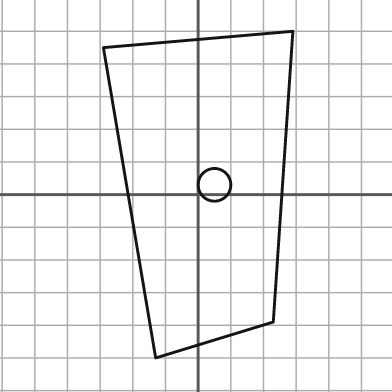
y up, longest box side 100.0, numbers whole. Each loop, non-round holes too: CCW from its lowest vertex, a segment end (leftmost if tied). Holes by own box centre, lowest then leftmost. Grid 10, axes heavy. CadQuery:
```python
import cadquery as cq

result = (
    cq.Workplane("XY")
    .moveTo(-13.0, -50.0)
    .lineTo(23.0, -39.0)
    .lineTo(29.0, 50.0)
    .lineTo(-29.0, 45.0)
    .close()
    .moveTo(5.0, 3.0)
    .circle(5.0)
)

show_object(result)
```